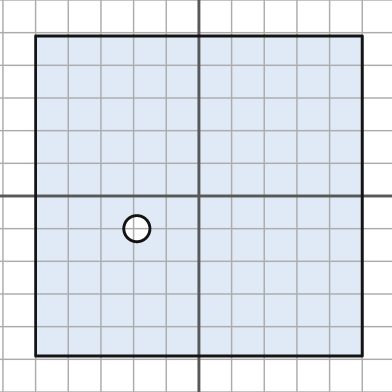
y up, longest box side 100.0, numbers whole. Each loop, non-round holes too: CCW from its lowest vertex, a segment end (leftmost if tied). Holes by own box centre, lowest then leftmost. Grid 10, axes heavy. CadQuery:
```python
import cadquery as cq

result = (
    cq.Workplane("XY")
    .moveTo(-50.0, -49.0)
    .lineTo(50.0, -49.0)
    .lineTo(50.0, 49.0)
    .lineTo(-50.0, 49.0)
    .close()
    .moveTo(-19.0, -10.0)
    .circle(4.0)
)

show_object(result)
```